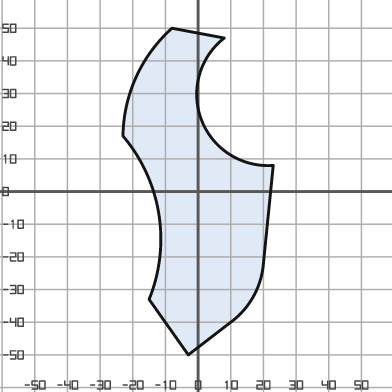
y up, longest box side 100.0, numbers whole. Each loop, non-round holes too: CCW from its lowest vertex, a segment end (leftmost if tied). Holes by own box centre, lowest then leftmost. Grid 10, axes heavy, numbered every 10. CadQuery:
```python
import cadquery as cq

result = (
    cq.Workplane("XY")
    .moveTo(-3.0, -50.0)
    .lineTo(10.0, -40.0)
    .threePointArc((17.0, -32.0), (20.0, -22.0))
    .lineTo(23.0, 8.0)
    .threePointArc((1.0, 22.0), (8.0, 47.0))
    .lineTo(-8.0, 50.0)
    .threePointArc((-19.0, 35.0), (-23.0, 17.0))
    .threePointArc((-12.0, -7.0), (-15.0, -33.0))
    .close()
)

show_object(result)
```